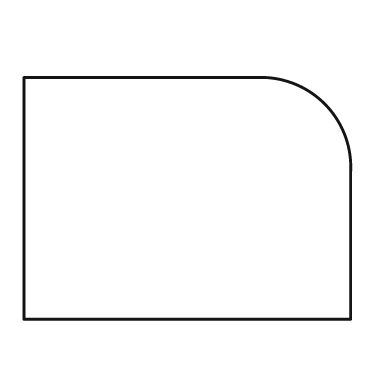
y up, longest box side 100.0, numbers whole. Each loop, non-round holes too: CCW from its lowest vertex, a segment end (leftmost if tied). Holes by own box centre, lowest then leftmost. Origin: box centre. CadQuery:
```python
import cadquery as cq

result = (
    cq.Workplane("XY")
    .moveTo(-50.0, -37.0)
    .lineTo(50.0, -37.0)
    .lineTo(50.0, 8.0)
    .threePointArc((42.0, 29.0), (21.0, 37.0))
    .lineTo(-50.0, 37.0)
    .close()
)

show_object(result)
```